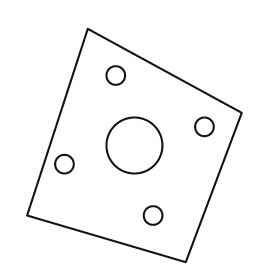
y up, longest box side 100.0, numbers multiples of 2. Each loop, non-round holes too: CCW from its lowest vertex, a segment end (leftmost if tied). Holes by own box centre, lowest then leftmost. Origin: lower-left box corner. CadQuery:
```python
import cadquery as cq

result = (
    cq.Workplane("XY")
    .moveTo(68.0, 0.0)
    .lineTo(92.0, 64.0)
    .lineTo(26.0, 100.0)
    .lineTo(0.0, 20.0)
    .close()
    .moveTo(54.0, 20.0)
    .circle(4.0)
    .moveTo(16.0, 42.0)
    .circle(4.0)
    .moveTo(46.0, 50.0)
    .circle(12.0)
    .moveTo(76.0, 58.0)
    .circle(4.0)
    .moveTo(38.0, 80.0)
    .circle(4.0)
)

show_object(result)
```